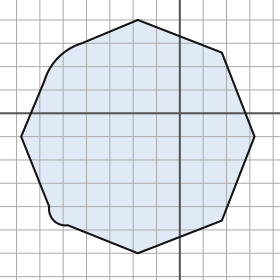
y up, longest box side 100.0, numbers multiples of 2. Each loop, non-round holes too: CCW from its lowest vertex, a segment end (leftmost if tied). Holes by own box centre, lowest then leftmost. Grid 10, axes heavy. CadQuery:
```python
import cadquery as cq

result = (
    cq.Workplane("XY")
    .moveTo(-18.0, -60.0)
    .lineTo(18.0, -46.0)
    .lineTo(32.0, -10.0)
    .lineTo(18.0, 26.0)
    .lineTo(-18.0, 40.0)
    .lineTo(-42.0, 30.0)
    .threePointArc((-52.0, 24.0), (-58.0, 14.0))
    .lineTo(-68.0, -10.0)
    .lineTo(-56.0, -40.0)
    .threePointArc((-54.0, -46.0), (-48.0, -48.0))
    .close()
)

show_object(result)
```